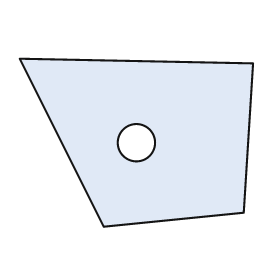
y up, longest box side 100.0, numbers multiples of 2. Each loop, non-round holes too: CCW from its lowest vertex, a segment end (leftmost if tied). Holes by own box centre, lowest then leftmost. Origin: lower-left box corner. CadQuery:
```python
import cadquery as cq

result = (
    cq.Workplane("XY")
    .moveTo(36.0, 0.0)
    .lineTo(96.0, 6.0)
    .lineTo(100.0, 70.0)
    .lineTo(0.0, 72.0)
    .close()
    .moveTo(50.0, 36.0)
    .circle(8.0)
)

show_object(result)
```